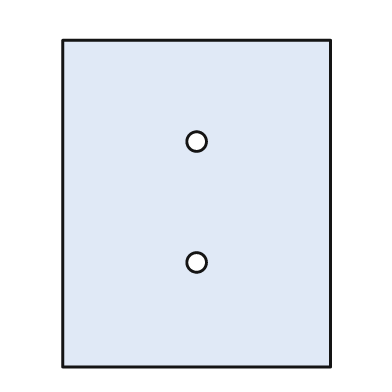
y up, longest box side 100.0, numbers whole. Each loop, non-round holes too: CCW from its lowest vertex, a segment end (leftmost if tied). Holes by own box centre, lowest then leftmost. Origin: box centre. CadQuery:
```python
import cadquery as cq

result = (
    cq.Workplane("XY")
    .moveTo(-41.0, -50.0)
    .lineTo(41.0, -50.0)
    .lineTo(41.0, 50.0)
    .lineTo(-41.0, 50.0)
    .close()
    .moveTo(0.0, -18.0)
    .circle(3.0)
    .moveTo(0.0, 19.0)
    .circle(3.0)
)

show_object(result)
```